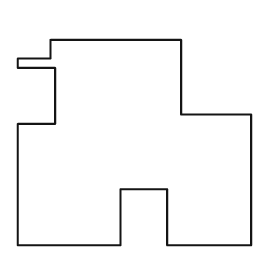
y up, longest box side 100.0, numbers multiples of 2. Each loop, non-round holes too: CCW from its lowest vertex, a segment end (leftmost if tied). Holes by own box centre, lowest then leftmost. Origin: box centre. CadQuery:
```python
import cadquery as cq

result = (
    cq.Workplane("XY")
    .moveTo(-50.0, -44.0)
    .lineTo(-6.0, -44.0)
    .lineTo(-6.0, -20.0)
    .lineTo(14.0, -20.0)
    .lineTo(14.0, -44.0)
    .lineTo(50.0, -44.0)
    .lineTo(50.0, 12.0)
    .lineTo(20.0, 12.0)
    .lineTo(20.0, 44.0)
    .lineTo(-36.0, 44.0)
    .lineTo(-36.0, 36.0)
    .lineTo(-50.0, 36.0)
    .lineTo(-50.0, 32.0)
    .lineTo(-34.0, 32.0)
    .lineTo(-34.0, 8.0)
    .lineTo(-50.0, 8.0)
    .close()
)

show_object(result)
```